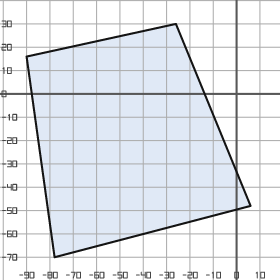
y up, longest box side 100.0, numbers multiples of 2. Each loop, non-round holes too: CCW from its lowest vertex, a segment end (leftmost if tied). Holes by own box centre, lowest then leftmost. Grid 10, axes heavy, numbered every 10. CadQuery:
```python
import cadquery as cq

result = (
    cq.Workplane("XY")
    .moveTo(-78.0, -70.0)
    .lineTo(6.0, -48.0)
    .lineTo(-26.0, 30.0)
    .lineTo(-90.0, 16.0)
    .close()
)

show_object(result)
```